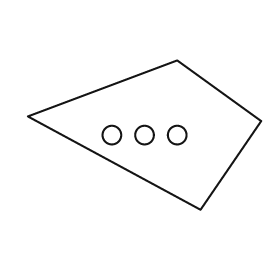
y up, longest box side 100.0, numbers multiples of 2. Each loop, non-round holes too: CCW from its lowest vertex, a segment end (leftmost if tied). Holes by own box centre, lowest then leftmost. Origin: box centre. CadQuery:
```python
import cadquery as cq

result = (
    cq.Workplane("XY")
    .moveTo(24.0, -32.0)
    .lineTo(50.0, 6.0)
    .lineTo(14.0, 32.0)
    .lineTo(-50.0, 8.0)
    .close()
    .moveTo(-14.0, 0.0)
    .circle(4.0)
    .moveTo(0.0, 0.0)
    .circle(4.0)
    .moveTo(14.0, 0.0)
    .circle(4.0)
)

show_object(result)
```